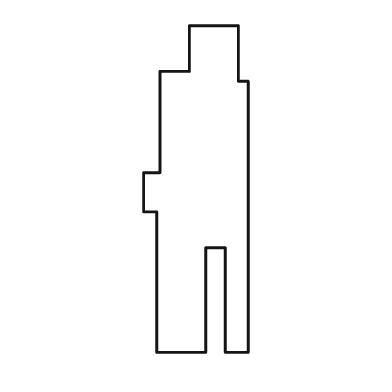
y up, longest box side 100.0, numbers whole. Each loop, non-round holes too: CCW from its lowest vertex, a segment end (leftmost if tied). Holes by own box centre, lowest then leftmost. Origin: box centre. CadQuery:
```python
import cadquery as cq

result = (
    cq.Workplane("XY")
    .moveTo(-12.0, -50.0)
    .lineTo(3.0, -50.0)
    .lineTo(3.0, -18.0)
    .lineTo(9.0, -18.0)
    .lineTo(9.0, -50.0)
    .lineTo(16.0, -50.0)
    .lineTo(16.0, 33.0)
    .lineTo(13.0, 33.0)
    .lineTo(13.0, 50.0)
    .lineTo(-2.0, 50.0)
    .lineTo(-2.0, 36.0)
    .lineTo(-11.0, 36.0)
    .lineTo(-11.0, 5.0)
    .lineTo(-16.0, 5.0)
    .lineTo(-16.0, -7.0)
    .lineTo(-12.0, -7.0)
    .close()
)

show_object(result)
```